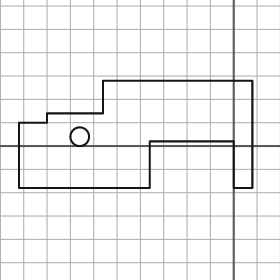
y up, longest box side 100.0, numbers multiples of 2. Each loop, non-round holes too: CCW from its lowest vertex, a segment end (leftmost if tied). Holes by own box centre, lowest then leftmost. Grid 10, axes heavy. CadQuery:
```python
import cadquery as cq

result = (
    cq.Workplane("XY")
    .moveTo(-92.0, -18.0)
    .lineTo(-36.0, -18.0)
    .lineTo(-36.0, 2.0)
    .lineTo(0.0, 2.0)
    .lineTo(0.0, -18.0)
    .lineTo(8.0, -18.0)
    .lineTo(8.0, 28.0)
    .lineTo(-56.0, 28.0)
    .lineTo(-56.0, 14.0)
    .lineTo(-80.0, 14.0)
    .lineTo(-80.0, 10.0)
    .lineTo(-92.0, 10.0)
    .close()
    .moveTo(-66.0, 4.0)
    .circle(4.0)
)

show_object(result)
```